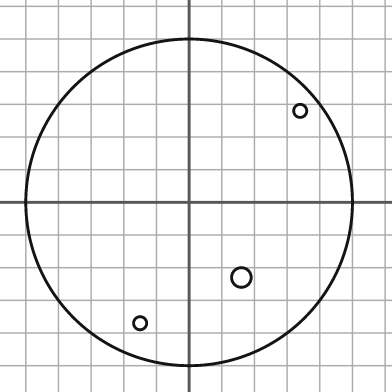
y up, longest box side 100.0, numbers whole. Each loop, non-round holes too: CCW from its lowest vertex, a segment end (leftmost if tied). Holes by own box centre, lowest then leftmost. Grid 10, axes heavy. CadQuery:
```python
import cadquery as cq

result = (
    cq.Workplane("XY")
    .moveTo(0.0, 0.0)
    .circle(50.0)
    .moveTo(-15.0, -37.0)
    .circle(2.0)
    .moveTo(16.0, -23.0)
    .circle(3.0)
    .moveTo(34.0, 28.0)
    .circle(2.0)
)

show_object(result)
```